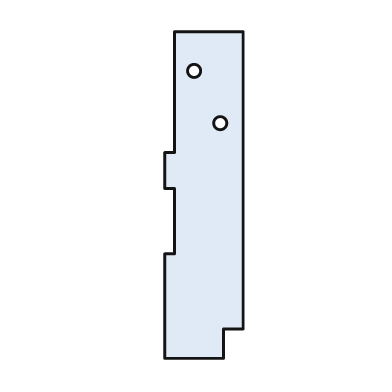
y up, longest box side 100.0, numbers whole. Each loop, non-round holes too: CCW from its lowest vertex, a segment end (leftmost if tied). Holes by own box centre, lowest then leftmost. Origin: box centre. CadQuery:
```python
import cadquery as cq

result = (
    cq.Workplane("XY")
    .moveTo(-12.0, -50.0)
    .lineTo(6.0, -50.0)
    .lineTo(6.0, -41.0)
    .lineTo(12.0, -41.0)
    .lineTo(12.0, 50.0)
    .lineTo(-9.0, 50.0)
    .lineTo(-9.0, 13.0)
    .lineTo(-12.0, 13.0)
    .lineTo(-12.0, 2.0)
    .lineTo(-9.0, 2.0)
    .lineTo(-9.0, -18.0)
    .lineTo(-12.0, -18.0)
    .close()
    .moveTo(5.0, 22.0)
    .circle(2.0)
    .moveTo(-3.0, 38.0)
    .circle(2.0)
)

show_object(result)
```